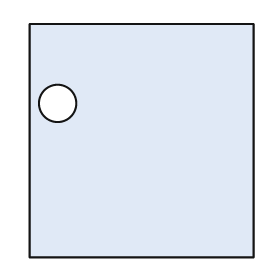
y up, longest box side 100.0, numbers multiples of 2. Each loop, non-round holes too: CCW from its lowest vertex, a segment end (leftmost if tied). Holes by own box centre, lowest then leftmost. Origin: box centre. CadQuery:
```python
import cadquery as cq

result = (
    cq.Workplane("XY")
    .moveTo(-48.0, -50.0)
    .lineTo(48.0, -50.0)
    .lineTo(48.0, 50.0)
    .lineTo(-48.0, 50.0)
    .close()
    .moveTo(-36.0, 16.0)
    .circle(8.0)
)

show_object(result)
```